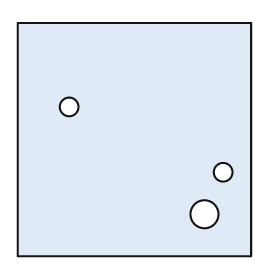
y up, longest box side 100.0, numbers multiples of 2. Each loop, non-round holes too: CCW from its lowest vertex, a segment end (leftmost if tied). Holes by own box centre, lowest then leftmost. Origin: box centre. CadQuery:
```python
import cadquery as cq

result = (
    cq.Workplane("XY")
    .moveTo(-50.0, -50.0)
    .lineTo(50.0, -50.0)
    .lineTo(50.0, 50.0)
    .lineTo(-50.0, 50.0)
    .close()
    .moveTo(30.0, -32.0)
    .circle(6.0)
    .moveTo(38.0, -14.0)
    .circle(4.0)
    .moveTo(-28.0, 14.0)
    .circle(4.0)
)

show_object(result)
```